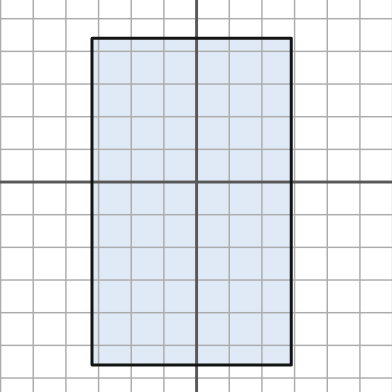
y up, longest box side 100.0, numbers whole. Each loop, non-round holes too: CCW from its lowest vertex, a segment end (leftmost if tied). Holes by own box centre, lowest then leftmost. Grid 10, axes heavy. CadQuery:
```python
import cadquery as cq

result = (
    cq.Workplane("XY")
    .moveTo(-32.0, -56.0)
    .lineTo(29.0, -56.0)
    .lineTo(29.0, 44.0)
    .lineTo(-32.0, 44.0)
    .close()
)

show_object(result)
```